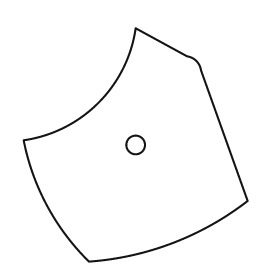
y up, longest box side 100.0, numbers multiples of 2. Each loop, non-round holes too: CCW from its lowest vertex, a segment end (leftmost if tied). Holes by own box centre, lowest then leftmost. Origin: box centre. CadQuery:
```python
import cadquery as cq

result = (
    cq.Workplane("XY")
    .moveTo(-20.0, -50.0)
    .threePointArc((16.0, -42.0), (48.0, -24.0))
    .lineTo(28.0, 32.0)
    .threePointArc((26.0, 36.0), (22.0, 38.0))
    .lineTo(0.0, 50.0)
    .threePointArc((-16.0, 18.0), (-48.0, 2.0))
    .threePointArc((-38.0, -26.0), (-20.0, -50.0))
    .close()
    .moveTo(0.0, 0.0)
    .circle(4.0)
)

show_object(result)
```